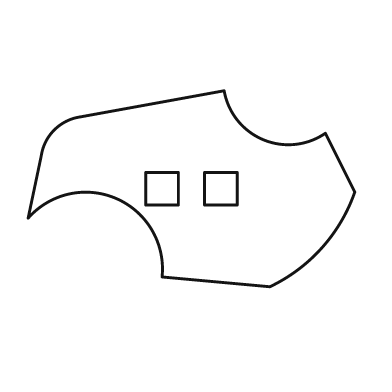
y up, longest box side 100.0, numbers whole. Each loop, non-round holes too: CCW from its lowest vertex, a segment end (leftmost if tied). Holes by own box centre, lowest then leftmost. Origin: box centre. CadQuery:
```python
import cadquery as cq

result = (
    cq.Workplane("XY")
    .moveTo(24.0, -30.0)
    .threePointArc((40.0, -18.0), (50.0, -1.0))
    .lineTo(41.0, 17.0)
    .threePointArc((22.0, 15.0), (10.0, 30.0))
    .lineTo(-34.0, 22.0)
    .threePointArc((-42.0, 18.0), (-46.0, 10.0))
    .lineTo(-50.0, -9.0)
    .threePointArc((-23.0, -3.0), (-9.0, -27.0))
    .close()
    .moveTo(-14.0, -5.0)
    .lineTo(-4.0, -5.0)
    .lineTo(-4.0, 5.0)
    .lineTo(-14.0, 5.0)
    .close()
    .moveTo(4.0, -5.0)
    .lineTo(14.0, -5.0)
    .lineTo(14.0, 5.0)
    .lineTo(4.0, 5.0)
    .close()
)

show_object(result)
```